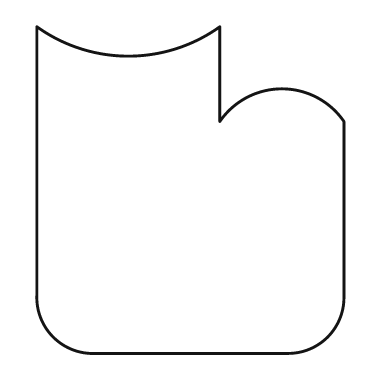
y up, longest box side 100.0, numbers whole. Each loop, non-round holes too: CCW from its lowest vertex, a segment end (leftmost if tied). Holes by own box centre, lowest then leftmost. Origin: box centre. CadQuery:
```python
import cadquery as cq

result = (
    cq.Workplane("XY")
    .moveTo(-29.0, -50.0)
    .lineTo(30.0, -50.0)
    .threePointArc((42.0, -45.0), (47.0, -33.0))
    .lineTo(47.0, 21.0)
    .threePointArc((28.0, 31.0), (9.0, 21.0))
    .lineTo(9.0, 50.0)
    .threePointArc((-19.0, 41.0), (-47.0, 50.0))
    .lineTo(-47.0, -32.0)
    .threePointArc((-42.0, -45.0), (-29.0, -50.0))
    .close()
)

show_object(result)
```